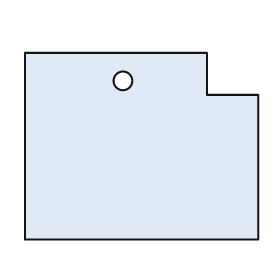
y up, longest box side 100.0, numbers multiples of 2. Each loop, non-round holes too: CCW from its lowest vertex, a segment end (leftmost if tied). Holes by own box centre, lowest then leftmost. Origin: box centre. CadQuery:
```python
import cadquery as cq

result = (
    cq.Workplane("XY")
    .moveTo(-50.0, -40.0)
    .lineTo(50.0, -40.0)
    .lineTo(50.0, 22.0)
    .lineTo(28.0, 22.0)
    .lineTo(28.0, 40.0)
    .lineTo(-50.0, 40.0)
    .close()
    .moveTo(-8.0, 28.0)
    .circle(4.0)
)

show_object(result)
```